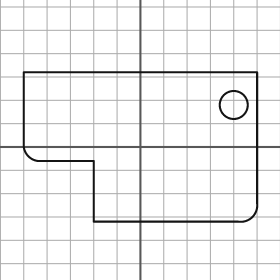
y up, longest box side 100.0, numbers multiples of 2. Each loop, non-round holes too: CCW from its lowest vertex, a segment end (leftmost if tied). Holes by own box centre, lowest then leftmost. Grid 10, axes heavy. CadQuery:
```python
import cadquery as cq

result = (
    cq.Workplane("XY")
    .moveTo(-20.0, -32.0)
    .lineTo(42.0, -32.0)
    .threePointArc((48.0, -30.0), (50.0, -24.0))
    .lineTo(50.0, 32.0)
    .lineTo(-50.0, 32.0)
    .lineTo(-50.0, 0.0)
    .threePointArc((-48.0, -4.0), (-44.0, -6.0))
    .lineTo(-20.0, -6.0)
    .close()
    .moveTo(40.0, 18.0)
    .circle(6.0)
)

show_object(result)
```